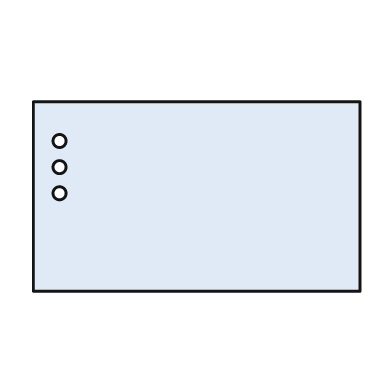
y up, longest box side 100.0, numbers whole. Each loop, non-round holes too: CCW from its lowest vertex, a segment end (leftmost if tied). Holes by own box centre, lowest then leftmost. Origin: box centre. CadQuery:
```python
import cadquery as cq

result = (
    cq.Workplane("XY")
    .moveTo(-50.0, -29.0)
    .lineTo(50.0, -29.0)
    .lineTo(50.0, 29.0)
    .lineTo(-50.0, 29.0)
    .close()
    .moveTo(-42.0, 1.0)
    .circle(2.0)
    .moveTo(-42.0, 9.0)
    .circle(2.0)
    .moveTo(-42.0, 17.0)
    .circle(2.0)
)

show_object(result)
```